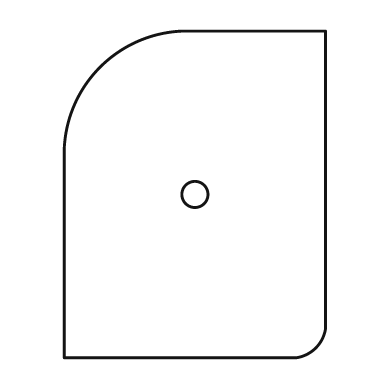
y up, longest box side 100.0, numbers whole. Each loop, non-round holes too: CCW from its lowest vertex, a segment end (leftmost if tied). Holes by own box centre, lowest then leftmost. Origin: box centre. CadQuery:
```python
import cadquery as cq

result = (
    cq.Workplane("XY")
    .moveTo(-40.0, -50.0)
    .lineTo(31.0, -50.0)
    .threePointArc((37.0, -47.0), (40.0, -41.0))
    .lineTo(40.0, 50.0)
    .lineTo(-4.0, 50.0)
    .threePointArc((-29.0, 39.0), (-40.0, 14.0))
    .close()
    .moveTo(0.0, 0.0)
    .circle(4.0)
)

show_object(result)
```